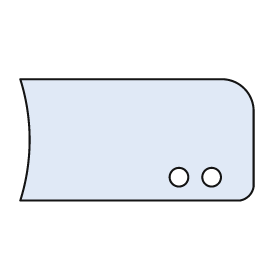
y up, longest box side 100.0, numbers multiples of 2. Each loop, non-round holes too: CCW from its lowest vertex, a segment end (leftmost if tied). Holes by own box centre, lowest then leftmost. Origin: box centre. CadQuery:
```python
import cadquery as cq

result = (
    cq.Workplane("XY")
    .moveTo(-50.0, -26.0)
    .lineTo(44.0, -26.0)
    .threePointArc((48.0, -24.0), (50.0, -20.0))
    .lineTo(50.0, 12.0)
    .threePointArc((46.0, 22.0), (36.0, 26.0))
    .lineTo(-50.0, 26.0)
    .threePointArc((-46.0, 0.0), (-50.0, -26.0))
    .close()
    .moveTo(18.0, -16.0)
    .circle(4.0)
    .moveTo(32.0, -16.0)
    .circle(4.0)
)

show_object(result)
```